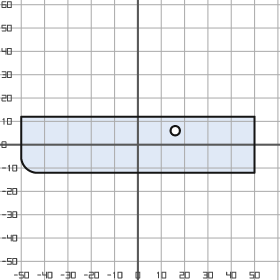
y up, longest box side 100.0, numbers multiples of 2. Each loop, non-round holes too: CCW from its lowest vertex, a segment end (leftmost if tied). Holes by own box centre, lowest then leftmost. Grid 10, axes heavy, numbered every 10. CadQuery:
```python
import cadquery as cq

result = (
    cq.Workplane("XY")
    .moveTo(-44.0, -12.0)
    .lineTo(50.0, -12.0)
    .lineTo(50.0, 12.0)
    .lineTo(-50.0, 12.0)
    .lineTo(-50.0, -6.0)
    .threePointArc((-48.0, -10.0), (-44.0, -12.0))
    .close()
    .moveTo(16.0, 6.0)
    .circle(2.0)
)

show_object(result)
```